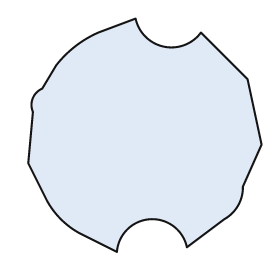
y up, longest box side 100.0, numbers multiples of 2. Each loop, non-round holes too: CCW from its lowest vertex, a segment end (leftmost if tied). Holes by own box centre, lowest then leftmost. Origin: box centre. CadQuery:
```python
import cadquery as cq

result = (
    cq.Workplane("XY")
    .moveTo(-12.0, -50.0)
    .threePointArc((2.0, -36.0), (18.0, -48.0))
    .lineTo(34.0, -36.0)
    .threePointArc((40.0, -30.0), (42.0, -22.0))
    .lineTo(50.0, -4.0)
    .lineTo(44.0, 24.0)
    .lineTo(24.0, 44.0)
    .threePointArc((8.0, 38.0), (-4.0, 50.0))
    .lineTo(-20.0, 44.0)
    .threePointArc((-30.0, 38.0), (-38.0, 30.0))
    .lineTo(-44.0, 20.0)
    .threePointArc((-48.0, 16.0), (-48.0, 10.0))
    .lineTo(-50.0, -12.0)
    .lineTo(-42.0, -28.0)
    .threePointArc((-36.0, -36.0), (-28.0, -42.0))
    .close()
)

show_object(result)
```